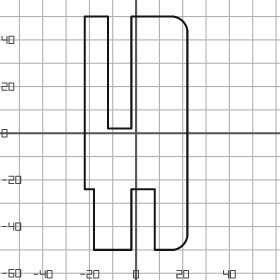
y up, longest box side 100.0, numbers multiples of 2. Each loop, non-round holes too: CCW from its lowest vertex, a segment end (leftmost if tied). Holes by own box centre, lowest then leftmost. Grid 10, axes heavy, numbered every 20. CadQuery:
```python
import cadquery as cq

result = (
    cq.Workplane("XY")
    .moveTo(-18.0, -50.0)
    .lineTo(-2.0, -50.0)
    .lineTo(-2.0, -24.0)
    .lineTo(8.0, -24.0)
    .lineTo(8.0, -50.0)
    .lineTo(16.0, -50.0)
    .threePointArc((20.0, -48.0), (22.0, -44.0))
    .lineTo(22.0, 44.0)
    .threePointArc((20.0, 48.0), (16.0, 50.0))
    .lineTo(-2.0, 50.0)
    .lineTo(-2.0, 2.0)
    .lineTo(-12.0, 2.0)
    .lineTo(-12.0, 50.0)
    .lineTo(-22.0, 50.0)
    .lineTo(-22.0, -24.0)
    .lineTo(-18.0, -24.0)
    .close()
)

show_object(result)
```